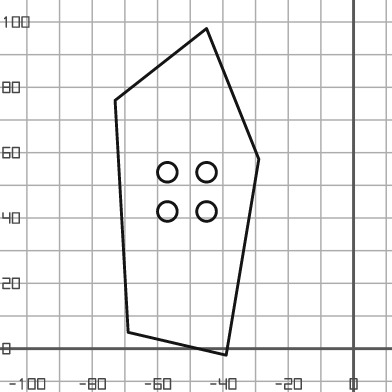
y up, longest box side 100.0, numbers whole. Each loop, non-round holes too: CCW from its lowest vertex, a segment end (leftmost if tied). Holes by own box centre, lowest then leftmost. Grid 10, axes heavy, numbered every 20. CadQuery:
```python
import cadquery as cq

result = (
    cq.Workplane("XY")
    .moveTo(-39.0, -2.0)
    .lineTo(-29.0, 58.0)
    .lineTo(-45.0, 98.0)
    .lineTo(-73.0, 76.0)
    .lineTo(-69.0, 5.0)
    .close()
    .moveTo(-57.0, 42.0)
    .circle(3.0)
    .moveTo(-45.0, 42.0)
    .circle(3.0)
    .moveTo(-57.0, 54.0)
    .circle(3.0)
    .moveTo(-45.0, 54.0)
    .circle(3.0)
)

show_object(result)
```